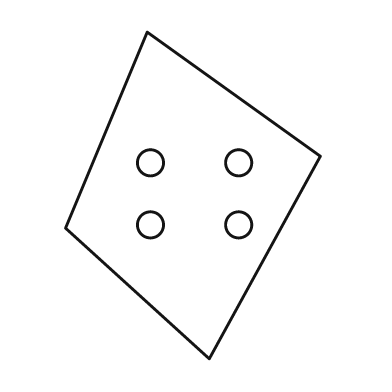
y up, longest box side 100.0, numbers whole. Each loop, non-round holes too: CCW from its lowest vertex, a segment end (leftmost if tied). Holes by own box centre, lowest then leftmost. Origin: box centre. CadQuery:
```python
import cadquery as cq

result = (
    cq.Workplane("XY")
    .moveTo(5.0, -50.0)
    .lineTo(39.0, 12.0)
    .lineTo(-14.0, 50.0)
    .lineTo(-39.0, -10.0)
    .close()
    .moveTo(-13.0, -9.0)
    .circle(4.0)
    .moveTo(14.0, -9.0)
    .circle(4.0)
    .moveTo(-13.0, 10.0)
    .circle(4.0)
    .moveTo(14.0, 10.0)
    .circle(4.0)
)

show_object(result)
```